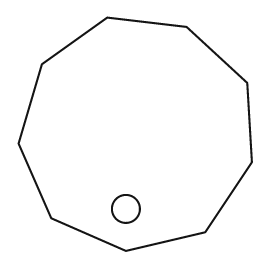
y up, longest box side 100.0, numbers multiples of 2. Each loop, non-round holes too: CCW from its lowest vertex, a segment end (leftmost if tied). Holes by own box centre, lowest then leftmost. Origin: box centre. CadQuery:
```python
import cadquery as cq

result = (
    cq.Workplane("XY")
    .moveTo(-4.0, -50.0)
    .lineTo(30.0, -42.0)
    .lineTo(50.0, -12.0)
    .lineTo(48.0, 22.0)
    .lineTo(22.0, 46.0)
    .lineTo(-12.0, 50.0)
    .lineTo(-40.0, 30.0)
    .lineTo(-50.0, -4.0)
    .lineTo(-36.0, -36.0)
    .close()
    .moveTo(-4.0, -32.0)
    .circle(6.0)
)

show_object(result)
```